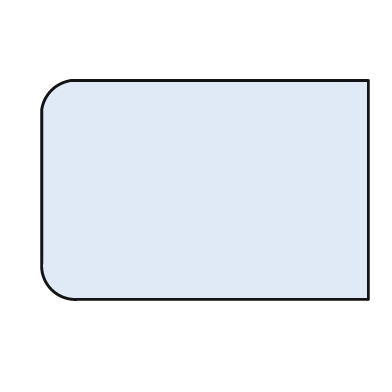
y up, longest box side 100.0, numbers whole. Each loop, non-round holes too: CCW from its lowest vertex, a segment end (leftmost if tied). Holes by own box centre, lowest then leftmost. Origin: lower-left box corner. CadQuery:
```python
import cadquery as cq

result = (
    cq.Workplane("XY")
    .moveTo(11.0, 0.0)
    .lineTo(100.0, 0.0)
    .lineTo(100.0, 67.0)
    .lineTo(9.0, 67.0)
    .threePointArc((3.0, 64.0), (0.0, 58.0))
    .lineTo(0.0, 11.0)
    .threePointArc((3.0, 3.0), (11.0, 0.0))
    .close()
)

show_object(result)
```